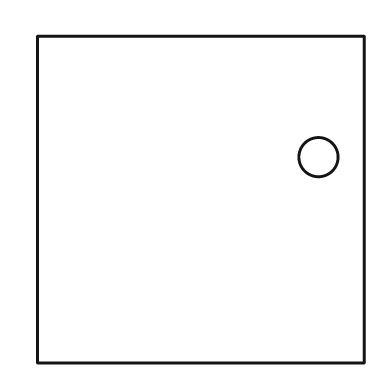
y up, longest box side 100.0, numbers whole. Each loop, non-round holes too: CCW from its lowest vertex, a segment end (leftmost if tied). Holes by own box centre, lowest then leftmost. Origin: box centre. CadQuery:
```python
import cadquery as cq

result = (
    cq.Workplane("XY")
    .moveTo(-50.0, -50.0)
    .lineTo(50.0, -50.0)
    .lineTo(50.0, 50.0)
    .lineTo(-50.0, 50.0)
    .close()
    .moveTo(36.0, 13.0)
    .circle(6.0)
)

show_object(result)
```